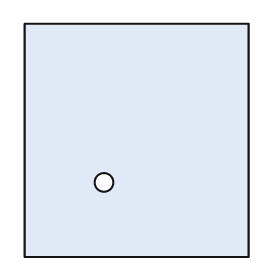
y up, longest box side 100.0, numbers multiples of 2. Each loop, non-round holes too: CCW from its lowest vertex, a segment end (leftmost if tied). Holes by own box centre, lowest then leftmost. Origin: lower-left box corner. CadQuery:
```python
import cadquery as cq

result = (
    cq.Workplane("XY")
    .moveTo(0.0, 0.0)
    .lineTo(96.0, 0.0)
    .lineTo(96.0, 100.0)
    .lineTo(0.0, 100.0)
    .close()
    .moveTo(34.0, 32.0)
    .circle(4.0)
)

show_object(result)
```